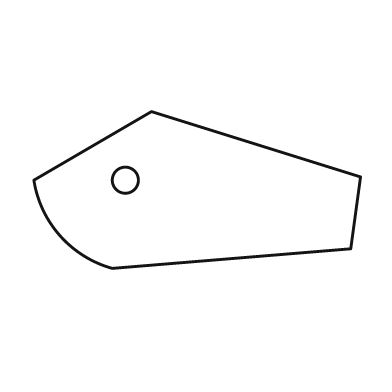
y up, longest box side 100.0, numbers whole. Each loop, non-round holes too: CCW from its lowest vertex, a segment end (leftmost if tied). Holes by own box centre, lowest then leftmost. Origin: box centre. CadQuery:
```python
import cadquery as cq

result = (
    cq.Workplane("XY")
    .moveTo(-26.0, -24.0)
    .lineTo(47.0, -18.0)
    .lineTo(50.0, 4.0)
    .lineTo(-14.0, 24.0)
    .lineTo(-50.0, 3.0)
    .threePointArc((-42.0, -14.0), (-26.0, -24.0))
    .close()
    .moveTo(-22.0, 3.0)
    .circle(4.0)
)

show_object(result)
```